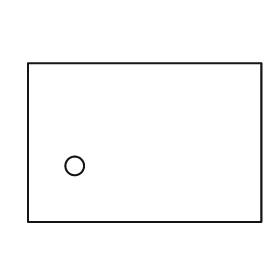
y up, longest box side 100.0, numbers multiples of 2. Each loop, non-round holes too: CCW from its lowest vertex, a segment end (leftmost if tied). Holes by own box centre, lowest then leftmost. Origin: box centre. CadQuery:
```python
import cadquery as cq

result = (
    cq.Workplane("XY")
    .moveTo(-50.0, -34.0)
    .lineTo(50.0, -34.0)
    .lineTo(50.0, 34.0)
    .lineTo(-50.0, 34.0)
    .close()
    .moveTo(-30.0, -10.0)
    .circle(4.0)
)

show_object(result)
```